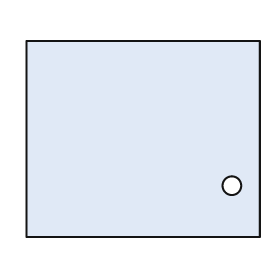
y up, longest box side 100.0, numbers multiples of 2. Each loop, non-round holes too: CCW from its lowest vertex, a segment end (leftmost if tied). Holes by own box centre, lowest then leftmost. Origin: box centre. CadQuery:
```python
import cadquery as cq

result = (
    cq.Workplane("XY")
    .moveTo(-50.0, -42.0)
    .lineTo(50.0, -42.0)
    .lineTo(50.0, 42.0)
    .lineTo(-50.0, 42.0)
    .close()
    .moveTo(38.0, -20.0)
    .circle(4.0)
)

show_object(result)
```